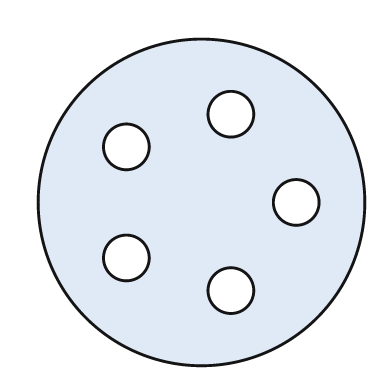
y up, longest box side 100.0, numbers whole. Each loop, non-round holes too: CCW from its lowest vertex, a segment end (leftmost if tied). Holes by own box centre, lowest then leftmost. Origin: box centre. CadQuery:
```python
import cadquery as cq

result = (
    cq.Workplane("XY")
    .moveTo(0.0, 0.0)
    .circle(50.0)
    .moveTo(9.0, -27.0)
    .circle(7.0)
    .moveTo(-23.0, -17.0)
    .circle(7.0)
    .moveTo(29.0, 0.0)
    .circle(7.0)
    .moveTo(-23.0, 17.0)
    .circle(7.0)
    .moveTo(9.0, 27.0)
    .circle(7.0)
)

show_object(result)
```